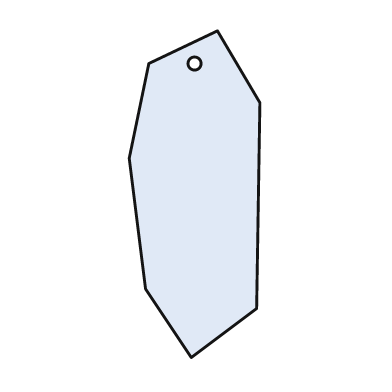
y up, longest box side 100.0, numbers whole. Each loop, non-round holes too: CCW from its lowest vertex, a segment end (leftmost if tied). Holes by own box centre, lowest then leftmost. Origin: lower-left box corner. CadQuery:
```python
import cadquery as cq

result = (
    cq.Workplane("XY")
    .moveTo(19.0, 0.0)
    .lineTo(39.0, 15.0)
    .lineTo(40.0, 78.0)
    .lineTo(27.0, 100.0)
    .lineTo(6.0, 90.0)
    .lineTo(0.0, 61.0)
    .lineTo(5.0, 21.0)
    .close()
    .moveTo(20.0, 90.0)
    .circle(2.0)
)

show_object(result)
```